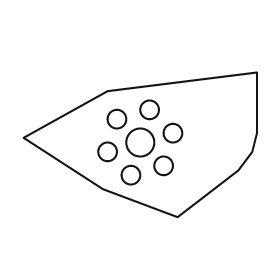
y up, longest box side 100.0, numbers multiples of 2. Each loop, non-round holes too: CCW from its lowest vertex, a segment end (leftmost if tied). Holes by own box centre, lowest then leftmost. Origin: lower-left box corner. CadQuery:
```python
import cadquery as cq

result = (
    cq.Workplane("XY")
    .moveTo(66.0, 0.0)
    .lineTo(92.0, 20.0)
    .lineTo(98.0, 28.0)
    .lineTo(100.0, 36.0)
    .lineTo(100.0, 62.0)
    .lineTo(36.0, 54.0)
    .lineTo(0.0, 34.0)
    .lineTo(34.0, 12.0)
    .close()
    .moveTo(46.0, 18.0)
    .circle(4.0)
    .moveTo(60.0, 22.0)
    .circle(4.0)
    .moveTo(36.0, 28.0)
    .circle(4.0)
    .moveTo(50.0, 32.0)
    .circle(6.0)
    .moveTo(64.0, 36.0)
    .circle(4.0)
    .moveTo(40.0, 42.0)
    .circle(4.0)
    .moveTo(54.0, 46.0)
    .circle(4.0)
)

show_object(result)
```